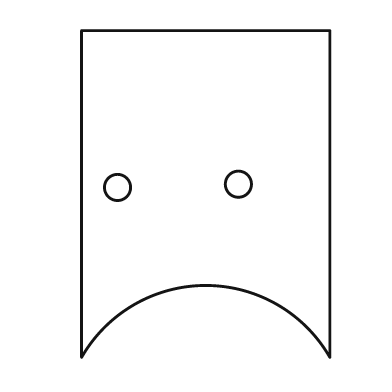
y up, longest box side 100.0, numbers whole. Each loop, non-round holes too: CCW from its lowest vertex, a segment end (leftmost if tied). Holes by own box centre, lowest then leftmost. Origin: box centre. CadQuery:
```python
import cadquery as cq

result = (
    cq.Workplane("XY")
    .moveTo(-38.0, -50.0)
    .threePointArc((0.0, -28.0), (38.0, -50.0))
    .lineTo(38.0, 50.0)
    .lineTo(-38.0, 50.0)
    .close()
    .moveTo(-27.0, 2.0)
    .circle(4.0)
    .moveTo(10.0, 3.0)
    .circle(4.0)
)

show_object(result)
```